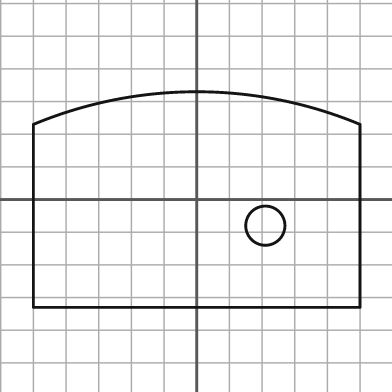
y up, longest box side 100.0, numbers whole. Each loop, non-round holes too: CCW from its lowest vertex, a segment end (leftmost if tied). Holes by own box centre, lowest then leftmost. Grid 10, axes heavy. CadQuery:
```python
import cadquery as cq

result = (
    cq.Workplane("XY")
    .moveTo(-50.0, -33.0)
    .lineTo(50.0, -33.0)
    .lineTo(50.0, 23.0)
    .threePointArc((0.0, 33.0), (-50.0, 23.0))
    .close()
    .moveTo(21.0, -8.0)
    .circle(6.0)
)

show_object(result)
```